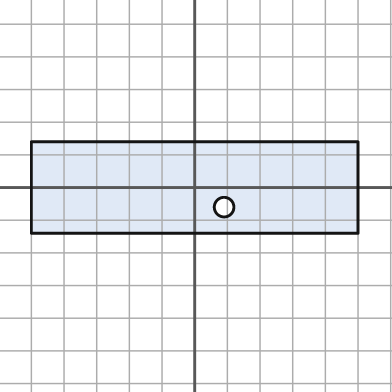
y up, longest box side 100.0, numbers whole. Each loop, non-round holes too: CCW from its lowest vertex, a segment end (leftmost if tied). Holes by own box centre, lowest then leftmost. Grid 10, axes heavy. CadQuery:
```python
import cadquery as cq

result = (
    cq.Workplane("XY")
    .moveTo(-50.0, -14.0)
    .lineTo(50.0, -14.0)
    .lineTo(50.0, 14.0)
    .lineTo(-50.0, 14.0)
    .close()
    .moveTo(9.0, -6.0)
    .circle(3.0)
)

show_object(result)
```